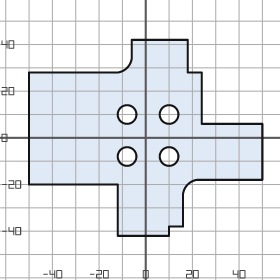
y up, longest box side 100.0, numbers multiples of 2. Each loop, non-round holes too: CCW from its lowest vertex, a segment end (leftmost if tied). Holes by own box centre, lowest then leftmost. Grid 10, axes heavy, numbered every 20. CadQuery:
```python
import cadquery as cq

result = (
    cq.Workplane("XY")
    .moveTo(-12.0, -42.0)
    .lineTo(10.0, -42.0)
    .lineTo(10.0, -38.0)
    .lineTo(16.0, -38.0)
    .lineTo(16.0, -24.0)
    .threePointArc((18.0, -20.0), (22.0, -18.0))
    .lineTo(50.0, -18.0)
    .lineTo(50.0, 6.0)
    .lineTo(24.0, 6.0)
    .lineTo(24.0, 28.0)
    .lineTo(18.0, 28.0)
    .lineTo(18.0, 42.0)
    .lineTo(-6.0, 42.0)
    .lineTo(-6.0, 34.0)
    .threePointArc((-8.0, 30.0), (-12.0, 28.0))
    .lineTo(-50.0, 28.0)
    .lineTo(-50.0, -20.0)
    .lineTo(-12.0, -20.0)
    .close()
    .moveTo(-8.0, -8.0)
    .circle(4.0)
    .moveTo(10.0, -8.0)
    .circle(4.0)
    .moveTo(-8.0, 10.0)
    .circle(4.0)
    .moveTo(10.0, 10.0)
    .circle(4.0)
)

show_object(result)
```